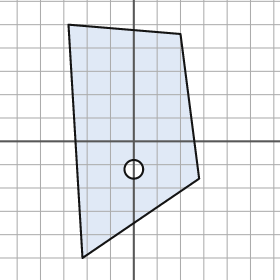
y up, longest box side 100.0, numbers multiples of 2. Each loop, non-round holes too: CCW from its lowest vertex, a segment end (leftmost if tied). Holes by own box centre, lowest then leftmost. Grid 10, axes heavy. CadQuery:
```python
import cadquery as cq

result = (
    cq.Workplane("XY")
    .moveTo(-22.0, -50.0)
    .lineTo(28.0, -16.0)
    .lineTo(20.0, 46.0)
    .lineTo(-28.0, 50.0)
    .close()
    .moveTo(0.0, -12.0)
    .circle(4.0)
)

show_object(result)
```